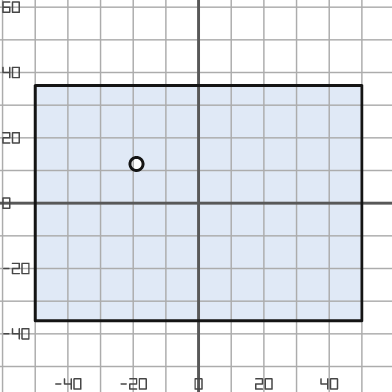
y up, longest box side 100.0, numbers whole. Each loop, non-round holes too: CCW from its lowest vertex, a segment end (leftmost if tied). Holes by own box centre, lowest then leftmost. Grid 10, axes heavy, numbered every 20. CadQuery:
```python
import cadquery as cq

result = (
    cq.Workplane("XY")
    .moveTo(-50.0, -36.0)
    .lineTo(50.0, -36.0)
    .lineTo(50.0, 36.0)
    .lineTo(-50.0, 36.0)
    .close()
    .moveTo(-19.0, 12.0)
    .circle(2.0)
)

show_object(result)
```